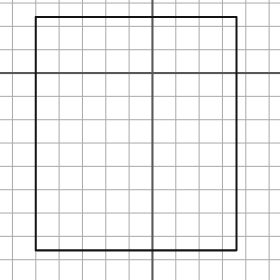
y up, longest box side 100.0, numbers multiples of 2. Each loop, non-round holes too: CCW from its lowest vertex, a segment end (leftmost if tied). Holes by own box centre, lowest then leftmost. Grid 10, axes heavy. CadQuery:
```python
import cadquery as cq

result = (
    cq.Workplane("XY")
    .moveTo(-50.0, -76.0)
    .lineTo(36.0, -76.0)
    .lineTo(36.0, 24.0)
    .lineTo(-50.0, 24.0)
    .close()
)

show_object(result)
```